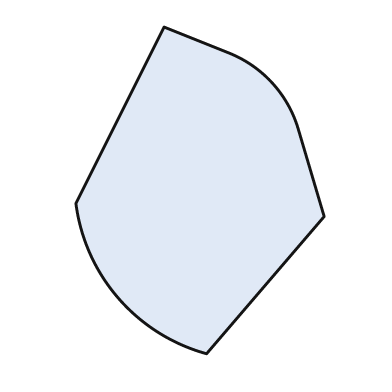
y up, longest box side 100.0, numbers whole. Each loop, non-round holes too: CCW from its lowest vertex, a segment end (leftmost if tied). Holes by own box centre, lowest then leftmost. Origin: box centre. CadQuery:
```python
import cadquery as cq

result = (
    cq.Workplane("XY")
    .moveTo(2.0, -50.0)
    .lineTo(38.0, -8.0)
    .lineTo(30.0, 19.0)
    .threePointArc((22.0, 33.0), (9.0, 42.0))
    .lineTo(-11.0, 50.0)
    .lineTo(-38.0, -4.0)
    .threePointArc((-25.0, -33.0), (2.0, -50.0))
    .close()
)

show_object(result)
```